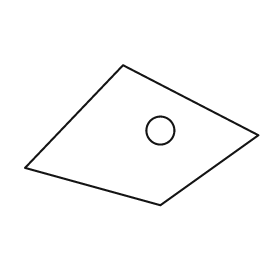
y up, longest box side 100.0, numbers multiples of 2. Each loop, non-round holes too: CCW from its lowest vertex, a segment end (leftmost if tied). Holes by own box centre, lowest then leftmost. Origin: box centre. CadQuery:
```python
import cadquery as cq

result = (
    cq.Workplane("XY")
    .moveTo(8.0, -30.0)
    .lineTo(50.0, 0.0)
    .lineTo(-8.0, 30.0)
    .lineTo(-50.0, -14.0)
    .close()
    .moveTo(8.0, 2.0)
    .circle(6.0)
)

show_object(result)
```